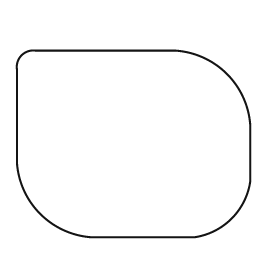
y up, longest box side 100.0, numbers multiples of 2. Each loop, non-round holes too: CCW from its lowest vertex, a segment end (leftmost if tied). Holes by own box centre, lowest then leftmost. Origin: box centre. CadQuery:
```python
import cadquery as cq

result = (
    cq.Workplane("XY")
    .moveTo(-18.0, -40.0)
    .lineTo(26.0, -40.0)
    .threePointArc((42.0, -32.0), (50.0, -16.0))
    .lineTo(50.0, 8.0)
    .threePointArc((40.0, 30.0), (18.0, 40.0))
    .lineTo(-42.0, 40.0)
    .threePointArc((-48.0, 38.0), (-50.0, 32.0))
    .lineTo(-50.0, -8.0)
    .threePointArc((-40.0, -30.0), (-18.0, -40.0))
    .close()
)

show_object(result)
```